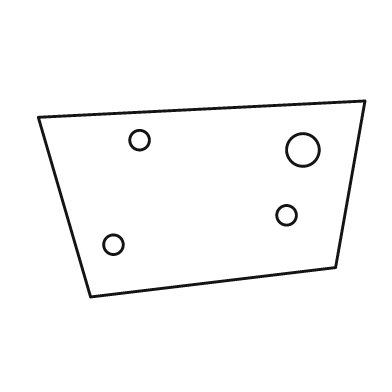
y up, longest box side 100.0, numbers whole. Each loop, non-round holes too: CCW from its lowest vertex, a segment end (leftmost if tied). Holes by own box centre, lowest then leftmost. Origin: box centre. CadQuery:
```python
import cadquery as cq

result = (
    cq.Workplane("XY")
    .moveTo(-34.0, -30.0)
    .lineTo(41.0, -21.0)
    .lineTo(50.0, 30.0)
    .lineTo(-50.0, 25.0)
    .close()
    .moveTo(-27.0, -14.0)
    .circle(3.0)
    .moveTo(26.0, -5.0)
    .circle(3.0)
    .moveTo(31.0, 15.0)
    .circle(5.0)
    .moveTo(-19.0, 18.0)
    .circle(3.0)
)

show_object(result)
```